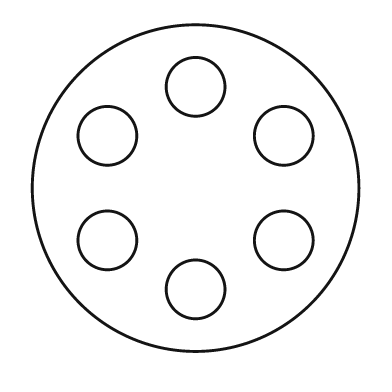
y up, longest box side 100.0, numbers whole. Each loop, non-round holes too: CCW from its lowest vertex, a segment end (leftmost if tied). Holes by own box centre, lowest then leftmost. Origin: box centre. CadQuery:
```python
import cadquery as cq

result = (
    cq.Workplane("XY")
    .moveTo(0.0, 0.0)
    .circle(50.0)
    .moveTo(0.0, -31.0)
    .circle(9.0)
    .moveTo(-27.0, -16.0)
    .circle(9.0)
    .moveTo(27.0, -16.0)
    .circle(9.0)
    .moveTo(-27.0, 16.0)
    .circle(9.0)
    .moveTo(27.0, 16.0)
    .circle(9.0)
    .moveTo(0.0, 31.0)
    .circle(9.0)
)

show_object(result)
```